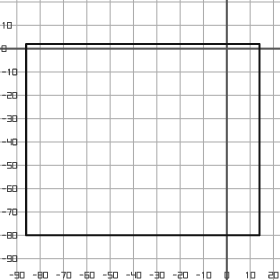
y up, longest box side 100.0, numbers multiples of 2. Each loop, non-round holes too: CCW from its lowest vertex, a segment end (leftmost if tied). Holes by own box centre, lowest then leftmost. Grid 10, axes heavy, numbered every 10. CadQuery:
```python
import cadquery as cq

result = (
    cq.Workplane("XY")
    .moveTo(-86.0, -80.0)
    .lineTo(14.0, -80.0)
    .lineTo(14.0, 2.0)
    .lineTo(-86.0, 2.0)
    .close()
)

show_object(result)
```